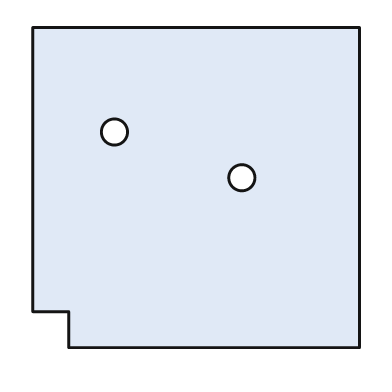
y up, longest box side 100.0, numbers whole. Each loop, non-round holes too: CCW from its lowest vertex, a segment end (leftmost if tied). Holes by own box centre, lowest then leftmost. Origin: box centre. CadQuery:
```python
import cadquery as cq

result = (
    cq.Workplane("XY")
    .moveTo(-39.0, -49.0)
    .lineTo(50.0, -49.0)
    .lineTo(50.0, 49.0)
    .lineTo(-50.0, 49.0)
    .lineTo(-50.0, -38.0)
    .lineTo(-39.0, -38.0)
    .close()
    .moveTo(14.0, 3.0)
    .circle(4.0)
    .moveTo(-25.0, 17.0)
    .circle(4.0)
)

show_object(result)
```